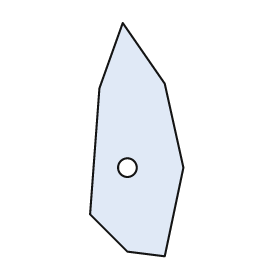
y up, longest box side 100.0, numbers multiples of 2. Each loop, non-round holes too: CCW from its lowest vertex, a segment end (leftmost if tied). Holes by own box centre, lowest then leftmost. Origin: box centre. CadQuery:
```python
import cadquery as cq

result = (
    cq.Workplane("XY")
    .moveTo(12.0, -50.0)
    .lineTo(20.0, -12.0)
    .lineTo(12.0, 24.0)
    .lineTo(-6.0, 50.0)
    .lineTo(-16.0, 22.0)
    .lineTo(-20.0, -32.0)
    .lineTo(-4.0, -48.0)
    .close()
    .moveTo(-4.0, -12.0)
    .circle(4.0)
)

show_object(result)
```